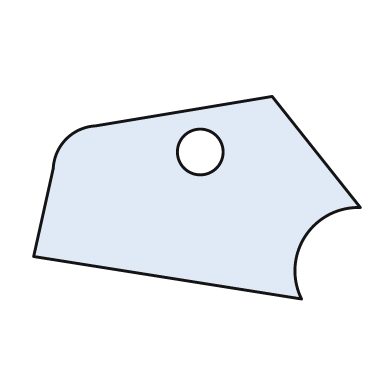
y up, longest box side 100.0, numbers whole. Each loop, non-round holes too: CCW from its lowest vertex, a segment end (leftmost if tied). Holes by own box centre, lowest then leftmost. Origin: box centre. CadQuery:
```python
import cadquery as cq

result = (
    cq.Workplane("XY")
    .moveTo(32.0, -31.0)
    .threePointArc((33.0, -12.0), (50.0, -3.0))
    .lineTo(23.0, 31.0)
    .lineTo(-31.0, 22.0)
    .threePointArc((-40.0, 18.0), (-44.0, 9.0))
    .lineTo(-50.0, -18.0)
    .close()
    .moveTo(1.0, 14.0)
    .circle(7.0)
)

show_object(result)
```